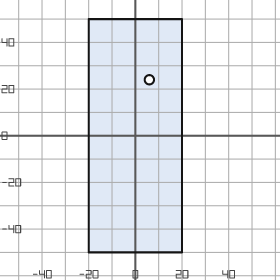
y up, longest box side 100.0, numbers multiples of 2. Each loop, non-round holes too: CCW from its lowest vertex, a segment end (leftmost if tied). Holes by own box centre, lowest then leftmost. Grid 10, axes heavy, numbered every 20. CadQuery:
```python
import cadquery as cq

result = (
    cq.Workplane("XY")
    .moveTo(-20.0, -50.0)
    .lineTo(20.0, -50.0)
    .lineTo(20.0, 50.0)
    .lineTo(-20.0, 50.0)
    .close()
    .moveTo(6.0, 24.0)
    .circle(2.0)
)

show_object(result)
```